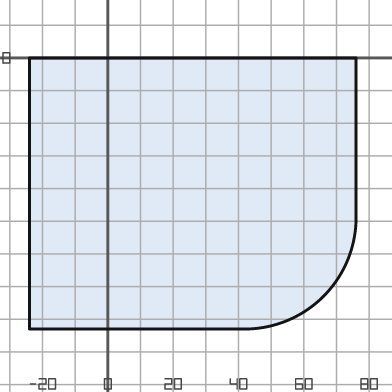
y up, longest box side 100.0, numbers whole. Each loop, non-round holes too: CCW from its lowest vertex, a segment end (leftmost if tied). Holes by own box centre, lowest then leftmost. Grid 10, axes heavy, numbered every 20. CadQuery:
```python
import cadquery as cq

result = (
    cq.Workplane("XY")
    .moveTo(-24.0, -83.0)
    .lineTo(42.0, -83.0)
    .threePointArc((66.0, -73.0), (76.0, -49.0))
    .lineTo(76.0, 0.0)
    .lineTo(-24.0, 0.0)
    .close()
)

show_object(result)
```